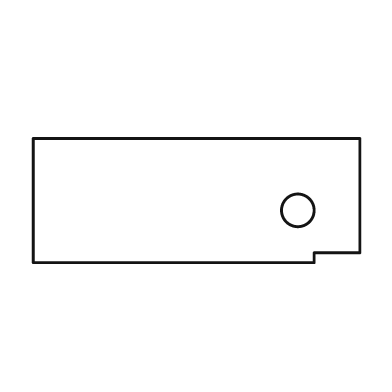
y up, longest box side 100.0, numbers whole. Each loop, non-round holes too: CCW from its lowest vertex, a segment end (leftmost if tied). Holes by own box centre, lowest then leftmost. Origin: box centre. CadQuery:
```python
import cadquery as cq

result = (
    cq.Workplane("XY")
    .moveTo(-50.0, -19.0)
    .lineTo(36.0, -19.0)
    .lineTo(36.0, -16.0)
    .lineTo(50.0, -16.0)
    .lineTo(50.0, 19.0)
    .lineTo(-50.0, 19.0)
    .close()
    .moveTo(31.0, -3.0)
    .circle(5.0)
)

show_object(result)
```